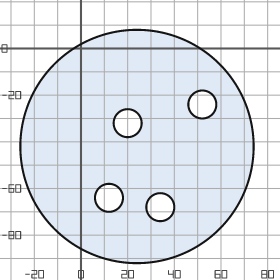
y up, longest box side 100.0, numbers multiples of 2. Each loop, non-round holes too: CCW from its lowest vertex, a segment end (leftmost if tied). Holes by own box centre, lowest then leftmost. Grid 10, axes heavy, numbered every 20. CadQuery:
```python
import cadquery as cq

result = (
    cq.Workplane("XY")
    .moveTo(24.0, -42.0)
    .circle(50.0)
    .moveTo(34.0, -68.0)
    .circle(6.0)
    .moveTo(12.0, -64.0)
    .circle(6.0)
    .moveTo(20.0, -32.0)
    .circle(6.0)
    .moveTo(52.0, -24.0)
    .circle(6.0)
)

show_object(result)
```